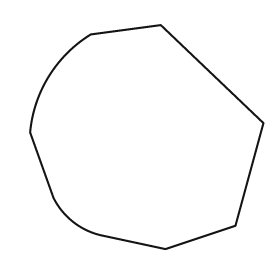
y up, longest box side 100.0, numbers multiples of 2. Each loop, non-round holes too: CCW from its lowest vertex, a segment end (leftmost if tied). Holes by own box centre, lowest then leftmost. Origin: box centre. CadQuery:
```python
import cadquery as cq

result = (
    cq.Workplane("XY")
    .moveTo(8.0, -48.0)
    .lineTo(38.0, -38.0)
    .lineTo(50.0, 6.0)
    .lineTo(6.0, 48.0)
    .lineTo(-24.0, 44.0)
    .threePointArc((-42.0, 26.0), (-50.0, 2.0))
    .lineTo(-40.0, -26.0)
    .threePointArc((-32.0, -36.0), (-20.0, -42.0))
    .close()
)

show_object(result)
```